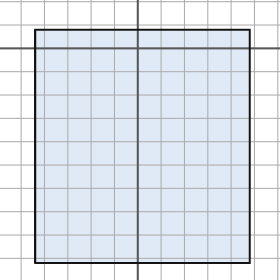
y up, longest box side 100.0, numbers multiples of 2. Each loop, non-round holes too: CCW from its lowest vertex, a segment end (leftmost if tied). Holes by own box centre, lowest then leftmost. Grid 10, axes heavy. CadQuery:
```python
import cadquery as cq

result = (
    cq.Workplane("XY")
    .moveTo(-44.0, -92.0)
    .lineTo(48.0, -92.0)
    .lineTo(48.0, 8.0)
    .lineTo(-44.0, 8.0)
    .close()
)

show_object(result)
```